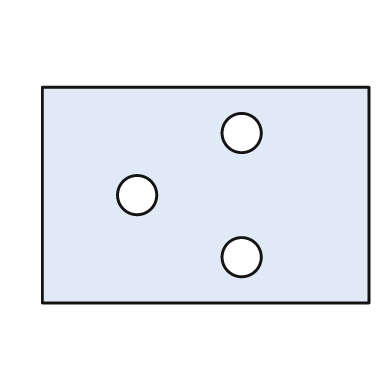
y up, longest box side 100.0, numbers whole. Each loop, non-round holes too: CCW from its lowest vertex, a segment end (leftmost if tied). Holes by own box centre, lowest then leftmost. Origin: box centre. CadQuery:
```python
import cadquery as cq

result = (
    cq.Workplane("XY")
    .moveTo(-50.0, -33.0)
    .lineTo(50.0, -33.0)
    .lineTo(50.0, 33.0)
    .lineTo(-50.0, 33.0)
    .close()
    .moveTo(11.0, -19.0)
    .circle(6.0)
    .moveTo(-21.0, 0.0)
    .circle(6.0)
    .moveTo(11.0, 19.0)
    .circle(6.0)
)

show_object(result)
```